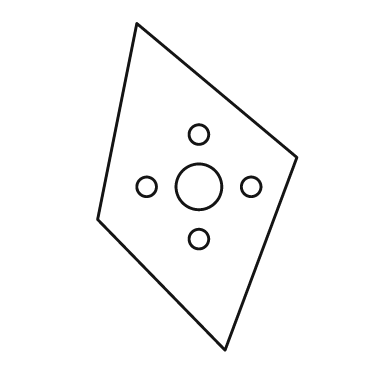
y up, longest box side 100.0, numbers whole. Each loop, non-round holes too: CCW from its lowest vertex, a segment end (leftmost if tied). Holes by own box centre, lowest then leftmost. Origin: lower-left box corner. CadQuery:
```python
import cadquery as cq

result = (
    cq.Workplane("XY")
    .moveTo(39.0, 0.0)
    .lineTo(61.0, 59.0)
    .lineTo(12.0, 100.0)
    .lineTo(0.0, 40.0)
    .close()
    .moveTo(31.0, 34.0)
    .circle(3.0)
    .moveTo(15.0, 50.0)
    .circle(3.0)
    .moveTo(31.0, 50.0)
    .circle(7.0)
    .moveTo(47.0, 50.0)
    .circle(3.0)
    .moveTo(31.0, 66.0)
    .circle(3.0)
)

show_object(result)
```